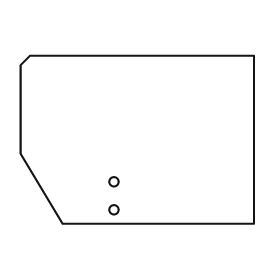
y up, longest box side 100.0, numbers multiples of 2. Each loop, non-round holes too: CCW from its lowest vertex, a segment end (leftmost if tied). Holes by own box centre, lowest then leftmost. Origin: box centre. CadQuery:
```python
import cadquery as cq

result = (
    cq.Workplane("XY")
    .moveTo(-32.0, -36.0)
    .lineTo(50.0, -36.0)
    .lineTo(50.0, 36.0)
    .lineTo(-46.0, 36.0)
    .lineTo(-50.0, 32.0)
    .lineTo(-50.0, -6.0)
    .close()
    .moveTo(-10.0, -30.0)
    .circle(2.0)
    .moveTo(-10.0, -18.0)
    .circle(2.0)
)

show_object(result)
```